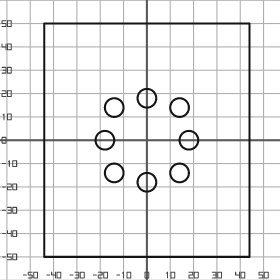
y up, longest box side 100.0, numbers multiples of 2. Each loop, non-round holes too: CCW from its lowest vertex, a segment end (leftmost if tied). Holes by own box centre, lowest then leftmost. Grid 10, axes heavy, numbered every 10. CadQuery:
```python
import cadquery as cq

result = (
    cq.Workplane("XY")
    .moveTo(-44.0, -50.0)
    .lineTo(44.0, -50.0)
    .lineTo(44.0, 50.0)
    .lineTo(-44.0, 50.0)
    .close()
    .moveTo(0.0, -18.0)
    .circle(4.0)
    .moveTo(-14.0, -14.0)
    .circle(4.0)
    .moveTo(14.0, -14.0)
    .circle(4.0)
    .moveTo(-18.0, 0.0)
    .circle(4.0)
    .moveTo(18.0, 0.0)
    .circle(4.0)
    .moveTo(-14.0, 14.0)
    .circle(4.0)
    .moveTo(14.0, 14.0)
    .circle(4.0)
    .moveTo(0.0, 18.0)
    .circle(4.0)
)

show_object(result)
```